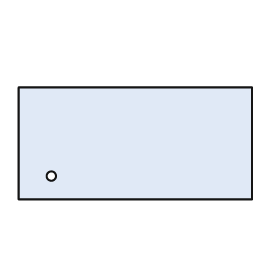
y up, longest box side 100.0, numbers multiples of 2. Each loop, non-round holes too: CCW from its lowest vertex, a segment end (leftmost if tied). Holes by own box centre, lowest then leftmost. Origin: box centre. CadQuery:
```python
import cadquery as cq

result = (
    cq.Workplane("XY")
    .moveTo(-50.0, -24.0)
    .lineTo(50.0, -24.0)
    .lineTo(50.0, 24.0)
    .lineTo(-50.0, 24.0)
    .close()
    .moveTo(-36.0, -14.0)
    .circle(2.0)
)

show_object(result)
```